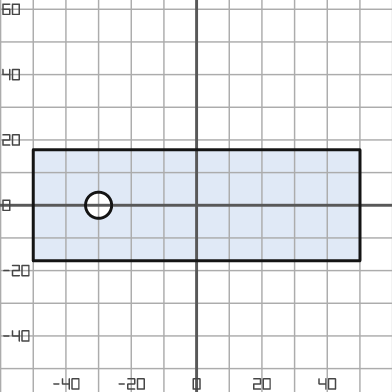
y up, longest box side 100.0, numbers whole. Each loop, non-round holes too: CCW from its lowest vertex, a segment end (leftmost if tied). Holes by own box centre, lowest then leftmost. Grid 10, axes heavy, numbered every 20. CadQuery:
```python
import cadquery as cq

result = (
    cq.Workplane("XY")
    .moveTo(-50.0, -17.0)
    .lineTo(50.0, -17.0)
    .lineTo(50.0, 17.0)
    .lineTo(-50.0, 17.0)
    .close()
    .moveTo(-30.0, 0.0)
    .circle(4.0)
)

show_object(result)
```